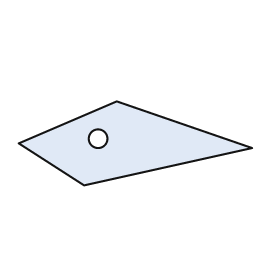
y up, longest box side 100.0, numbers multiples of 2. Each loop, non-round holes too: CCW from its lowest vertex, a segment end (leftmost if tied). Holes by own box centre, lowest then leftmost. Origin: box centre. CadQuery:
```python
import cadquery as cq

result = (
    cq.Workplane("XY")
    .moveTo(-22.0, -18.0)
    .lineTo(50.0, -2.0)
    .lineTo(-8.0, 18.0)
    .lineTo(-50.0, 0.0)
    .close()
    .moveTo(-16.0, 2.0)
    .circle(4.0)
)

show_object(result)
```